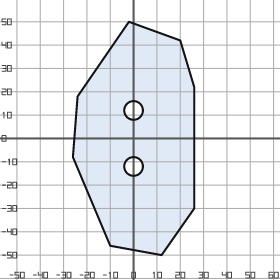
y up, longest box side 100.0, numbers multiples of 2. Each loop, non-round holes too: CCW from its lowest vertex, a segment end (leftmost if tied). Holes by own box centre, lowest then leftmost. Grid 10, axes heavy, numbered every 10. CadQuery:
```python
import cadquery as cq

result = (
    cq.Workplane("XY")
    .moveTo(12.0, -50.0)
    .lineTo(26.0, -30.0)
    .lineTo(26.0, 22.0)
    .lineTo(20.0, 42.0)
    .lineTo(-2.0, 50.0)
    .lineTo(-24.0, 18.0)
    .lineTo(-26.0, -8.0)
    .lineTo(-10.0, -46.0)
    .close()
    .moveTo(0.0, -12.0)
    .circle(4.0)
    .moveTo(0.0, 12.0)
    .circle(4.0)
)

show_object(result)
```